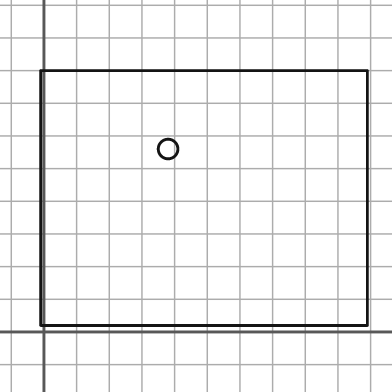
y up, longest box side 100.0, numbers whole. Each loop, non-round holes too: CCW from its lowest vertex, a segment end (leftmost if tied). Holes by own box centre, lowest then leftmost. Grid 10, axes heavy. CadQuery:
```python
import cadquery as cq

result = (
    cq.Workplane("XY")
    .moveTo(-1.0, 2.0)
    .lineTo(99.0, 2.0)
    .lineTo(99.0, 80.0)
    .lineTo(-1.0, 80.0)
    .close()
    .moveTo(38.0, 56.0)
    .circle(3.0)
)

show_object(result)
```